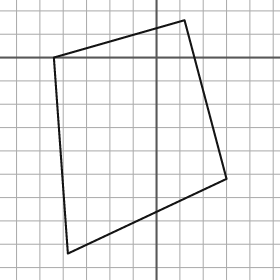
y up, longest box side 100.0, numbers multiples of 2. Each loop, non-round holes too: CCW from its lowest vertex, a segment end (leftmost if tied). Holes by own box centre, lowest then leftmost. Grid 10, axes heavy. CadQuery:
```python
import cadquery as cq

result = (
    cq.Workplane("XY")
    .moveTo(-38.0, -84.0)
    .lineTo(30.0, -52.0)
    .lineTo(12.0, 16.0)
    .lineTo(-44.0, 0.0)
    .close()
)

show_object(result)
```